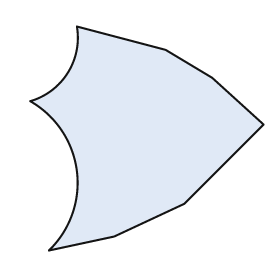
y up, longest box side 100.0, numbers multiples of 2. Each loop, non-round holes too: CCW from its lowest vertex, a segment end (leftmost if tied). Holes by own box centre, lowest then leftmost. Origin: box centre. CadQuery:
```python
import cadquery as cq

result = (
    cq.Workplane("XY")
    .moveTo(-42.0, -48.0)
    .lineTo(-14.0, -42.0)
    .lineTo(16.0, -28.0)
    .lineTo(50.0, 6.0)
    .lineTo(28.0, 26.0)
    .lineTo(8.0, 38.0)
    .lineTo(-30.0, 48.0)
    .threePointArc((-34.0, 28.0), (-50.0, 16.0))
    .threePointArc((-30.0, -14.0), (-42.0, -48.0))
    .close()
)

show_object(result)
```